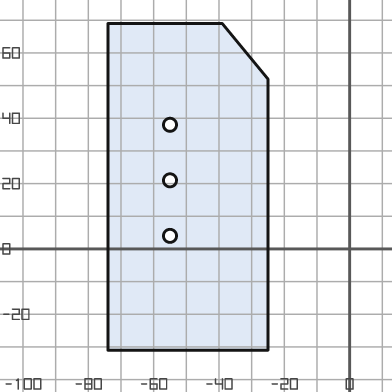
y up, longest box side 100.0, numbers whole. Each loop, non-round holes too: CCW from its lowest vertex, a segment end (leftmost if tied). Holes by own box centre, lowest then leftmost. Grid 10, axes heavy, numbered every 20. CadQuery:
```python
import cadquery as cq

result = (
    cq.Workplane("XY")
    .moveTo(-74.0, -31.0)
    .lineTo(-25.0, -31.0)
    .lineTo(-25.0, 52.0)
    .lineTo(-39.0, 69.0)
    .lineTo(-74.0, 69.0)
    .close()
    .moveTo(-55.0, 4.0)
    .circle(2.0)
    .moveTo(-55.0, 21.0)
    .circle(2.0)
    .moveTo(-55.0, 38.0)
    .circle(2.0)
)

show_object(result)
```